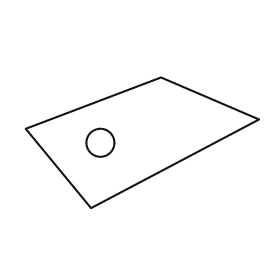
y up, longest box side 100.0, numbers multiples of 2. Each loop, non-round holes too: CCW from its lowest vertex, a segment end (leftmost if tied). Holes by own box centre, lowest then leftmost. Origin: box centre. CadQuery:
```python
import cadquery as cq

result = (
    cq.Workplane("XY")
    .moveTo(-22.0, -28.0)
    .lineTo(50.0, 10.0)
    .lineTo(8.0, 28.0)
    .lineTo(-50.0, 6.0)
    .close()
    .moveTo(-18.0, 0.0)
    .circle(6.0)
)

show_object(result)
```